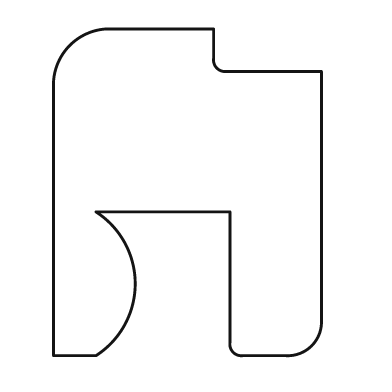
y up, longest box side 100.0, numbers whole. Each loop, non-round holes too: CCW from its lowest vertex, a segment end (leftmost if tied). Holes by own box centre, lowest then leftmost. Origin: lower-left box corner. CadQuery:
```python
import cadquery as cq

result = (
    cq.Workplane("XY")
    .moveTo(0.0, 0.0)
    .lineTo(13.0, 0.0)
    .threePointArc((25.0, 22.0), (13.0, 44.0))
    .lineTo(54.0, 44.0)
    .lineTo(54.0, 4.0)
    .threePointArc((55.0, 1.0), (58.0, 0.0))
    .lineTo(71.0, 0.0)
    .threePointArc((79.0, 3.0), (82.0, 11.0))
    .lineTo(82.0, 87.0)
    .lineTo(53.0, 87.0)
    .threePointArc((50.0, 88.0), (49.0, 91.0))
    .lineTo(49.0, 100.0)
    .lineTo(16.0, 100.0)
    .threePointArc((5.0, 95.0), (0.0, 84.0))
    .close()
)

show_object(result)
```